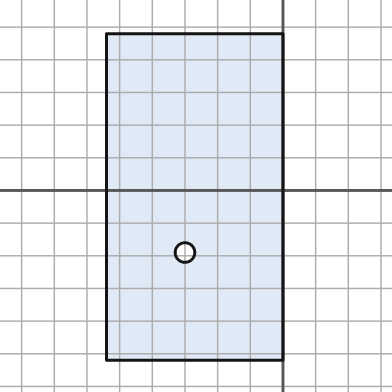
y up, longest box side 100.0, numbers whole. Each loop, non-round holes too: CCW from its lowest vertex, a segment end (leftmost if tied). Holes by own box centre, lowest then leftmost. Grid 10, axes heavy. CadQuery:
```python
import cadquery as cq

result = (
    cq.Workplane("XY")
    .moveTo(-54.0, -52.0)
    .lineTo(0.0, -52.0)
    .lineTo(0.0, 48.0)
    .lineTo(-54.0, 48.0)
    .close()
    .moveTo(-30.0, -19.0)
    .circle(3.0)
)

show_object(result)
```